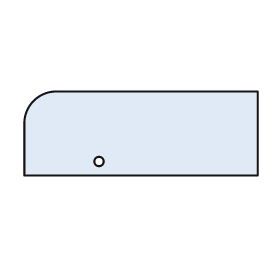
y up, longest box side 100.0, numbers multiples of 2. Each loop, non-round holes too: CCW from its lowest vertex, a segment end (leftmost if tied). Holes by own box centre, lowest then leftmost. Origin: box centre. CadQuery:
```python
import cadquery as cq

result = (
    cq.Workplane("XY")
    .moveTo(-50.0, -18.0)
    .lineTo(50.0, -18.0)
    .lineTo(50.0, 18.0)
    .lineTo(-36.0, 18.0)
    .threePointArc((-46.0, 14.0), (-50.0, 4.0))
    .close()
    .moveTo(-18.0, -12.0)
    .circle(2.0)
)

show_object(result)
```